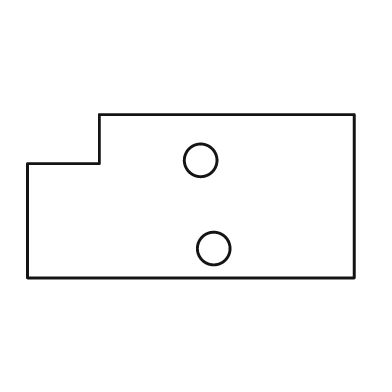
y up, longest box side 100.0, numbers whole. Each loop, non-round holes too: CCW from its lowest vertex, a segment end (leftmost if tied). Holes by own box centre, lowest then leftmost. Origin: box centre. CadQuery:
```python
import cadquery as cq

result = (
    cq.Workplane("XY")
    .moveTo(-50.0, -25.0)
    .lineTo(50.0, -25.0)
    .lineTo(50.0, 25.0)
    .lineTo(-28.0, 25.0)
    .lineTo(-28.0, 10.0)
    .lineTo(-50.0, 10.0)
    .close()
    .moveTo(7.0, -16.0)
    .circle(5.0)
    .moveTo(3.0, 11.0)
    .circle(5.0)
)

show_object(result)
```